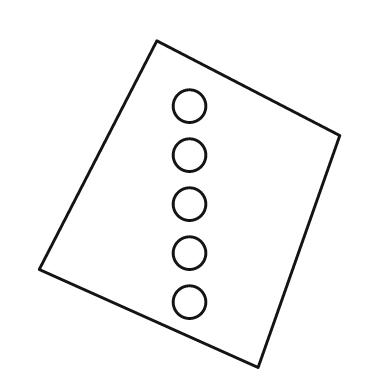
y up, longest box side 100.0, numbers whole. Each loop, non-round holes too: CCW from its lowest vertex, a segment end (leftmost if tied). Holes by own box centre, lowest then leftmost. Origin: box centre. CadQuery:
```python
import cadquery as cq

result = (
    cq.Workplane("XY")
    .moveTo(21.0, -50.0)
    .lineTo(46.0, 21.0)
    .lineTo(-10.0, 50.0)
    .lineTo(-46.0, -20.0)
    .close()
    .moveTo(0.0, -30.0)
    .circle(5.0)
    .moveTo(0.0, -15.0)
    .circle(5.0)
    .moveTo(0.0, 0.0)
    .circle(5.0)
    .moveTo(0.0, 15.0)
    .circle(5.0)
    .moveTo(0.0, 30.0)
    .circle(5.0)
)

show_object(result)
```